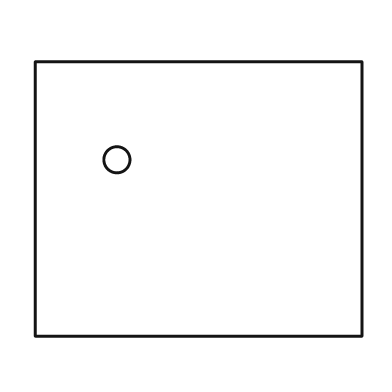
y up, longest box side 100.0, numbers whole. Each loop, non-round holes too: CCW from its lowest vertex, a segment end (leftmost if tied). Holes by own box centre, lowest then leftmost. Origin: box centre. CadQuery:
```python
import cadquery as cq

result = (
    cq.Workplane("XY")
    .moveTo(-50.0, -42.0)
    .lineTo(50.0, -42.0)
    .lineTo(50.0, 42.0)
    .lineTo(-50.0, 42.0)
    .close()
    .moveTo(-25.0, 12.0)
    .circle(4.0)
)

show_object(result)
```